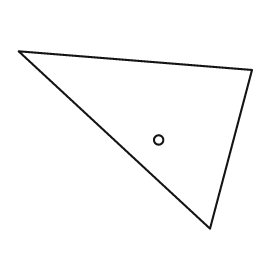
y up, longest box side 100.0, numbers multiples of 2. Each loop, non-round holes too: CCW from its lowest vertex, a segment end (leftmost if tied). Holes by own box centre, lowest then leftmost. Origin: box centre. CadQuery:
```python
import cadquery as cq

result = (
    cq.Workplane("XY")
    .moveTo(32.0, -38.0)
    .lineTo(50.0, 30.0)
    .lineTo(-50.0, 38.0)
    .close()
    .moveTo(10.0, 0.0)
    .circle(2.0)
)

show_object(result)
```